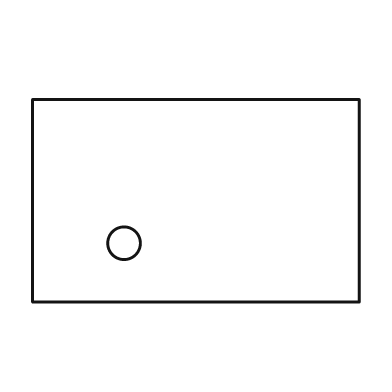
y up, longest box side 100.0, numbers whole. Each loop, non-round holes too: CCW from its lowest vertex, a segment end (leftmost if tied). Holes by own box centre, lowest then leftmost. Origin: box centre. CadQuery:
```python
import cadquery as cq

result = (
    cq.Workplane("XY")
    .moveTo(-50.0, -31.0)
    .lineTo(50.0, -31.0)
    .lineTo(50.0, 31.0)
    .lineTo(-50.0, 31.0)
    .close()
    .moveTo(-22.0, -13.0)
    .circle(5.0)
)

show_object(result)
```